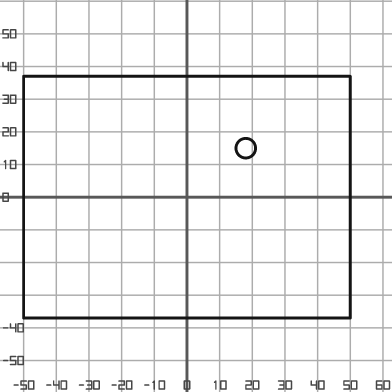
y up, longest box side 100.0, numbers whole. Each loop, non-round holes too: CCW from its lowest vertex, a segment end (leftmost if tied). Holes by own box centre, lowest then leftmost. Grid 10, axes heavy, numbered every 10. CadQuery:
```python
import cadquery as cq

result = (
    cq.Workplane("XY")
    .moveTo(-50.0, -37.0)
    .lineTo(50.0, -37.0)
    .lineTo(50.0, 37.0)
    .lineTo(-50.0, 37.0)
    .close()
    .moveTo(18.0, 15.0)
    .circle(3.0)
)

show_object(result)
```